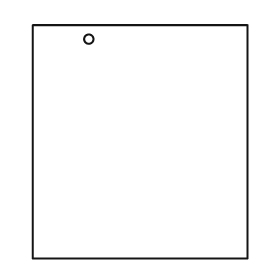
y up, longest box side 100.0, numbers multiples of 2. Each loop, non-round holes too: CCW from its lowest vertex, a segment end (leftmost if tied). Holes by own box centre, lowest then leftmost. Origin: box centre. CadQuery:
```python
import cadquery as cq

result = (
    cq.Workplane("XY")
    .moveTo(-46.0, -50.0)
    .lineTo(46.0, -50.0)
    .lineTo(46.0, 50.0)
    .lineTo(-46.0, 50.0)
    .close()
    .moveTo(-22.0, 44.0)
    .circle(2.0)
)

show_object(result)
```